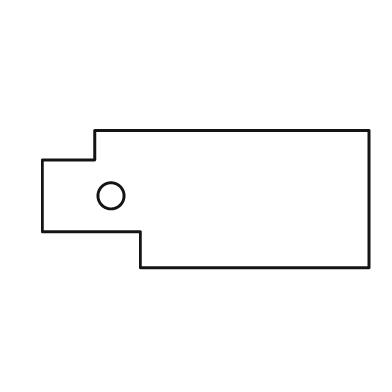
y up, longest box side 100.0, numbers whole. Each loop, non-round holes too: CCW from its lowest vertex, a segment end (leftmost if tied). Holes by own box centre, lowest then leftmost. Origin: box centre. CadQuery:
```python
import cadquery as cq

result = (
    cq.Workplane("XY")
    .moveTo(-20.0, -21.0)
    .lineTo(50.0, -21.0)
    .lineTo(50.0, 21.0)
    .lineTo(-34.0, 21.0)
    .lineTo(-34.0, 12.0)
    .lineTo(-50.0, 12.0)
    .lineTo(-50.0, -10.0)
    .lineTo(-20.0, -10.0)
    .close()
    .moveTo(-29.0, 1.0)
    .circle(4.0)
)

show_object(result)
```